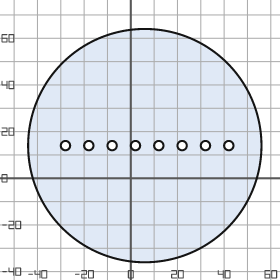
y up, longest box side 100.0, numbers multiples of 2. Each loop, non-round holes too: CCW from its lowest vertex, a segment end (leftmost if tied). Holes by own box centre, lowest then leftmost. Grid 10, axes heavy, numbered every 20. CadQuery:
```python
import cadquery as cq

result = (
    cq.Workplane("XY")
    .moveTo(6.0, 14.0)
    .circle(50.0)
    .moveTo(-28.0, 14.0)
    .circle(2.0)
    .moveTo(-18.0, 14.0)
    .circle(2.0)
    .moveTo(-8.0, 14.0)
    .circle(2.0)
    .moveTo(2.0, 14.0)
    .circle(2.0)
    .moveTo(12.0, 14.0)
    .circle(2.0)
    .moveTo(22.0, 14.0)
    .circle(2.0)
    .moveTo(32.0, 14.0)
    .circle(2.0)
    .moveTo(42.0, 14.0)
    .circle(2.0)
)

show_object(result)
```